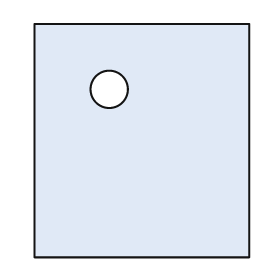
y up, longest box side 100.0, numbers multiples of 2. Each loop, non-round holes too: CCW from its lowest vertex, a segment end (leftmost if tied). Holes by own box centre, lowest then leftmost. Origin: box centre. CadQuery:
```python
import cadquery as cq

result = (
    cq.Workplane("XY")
    .moveTo(-46.0, -50.0)
    .lineTo(46.0, -50.0)
    .lineTo(46.0, 50.0)
    .lineTo(-46.0, 50.0)
    .close()
    .moveTo(-14.0, 22.0)
    .circle(8.0)
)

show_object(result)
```